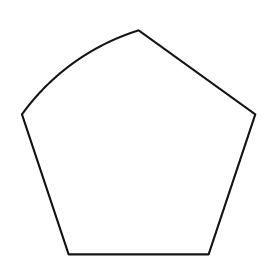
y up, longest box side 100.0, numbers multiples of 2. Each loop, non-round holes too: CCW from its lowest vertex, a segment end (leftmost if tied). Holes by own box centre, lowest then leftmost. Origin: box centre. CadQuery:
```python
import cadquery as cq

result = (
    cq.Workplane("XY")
    .moveTo(-30.0, -48.0)
    .lineTo(30.0, -48.0)
    .lineTo(50.0, 12.0)
    .lineTo(0.0, 48.0)
    .threePointArc((-28.0, 34.0), (-50.0, 12.0))
    .close()
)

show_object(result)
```